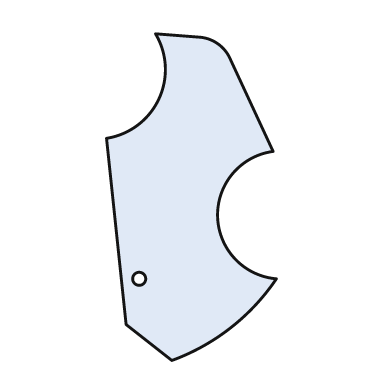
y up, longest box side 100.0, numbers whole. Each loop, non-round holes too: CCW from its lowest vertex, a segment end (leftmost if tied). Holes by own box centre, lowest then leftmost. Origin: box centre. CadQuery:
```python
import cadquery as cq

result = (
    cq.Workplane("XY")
    .moveTo(-6.0, -50.0)
    .threePointArc((12.0, -40.0), (26.0, -25.0))
    .threePointArc((8.0, -6.0), (25.0, 14.0))
    .lineTo(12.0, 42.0)
    .threePointArc((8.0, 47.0), (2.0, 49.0))
    .lineTo(-11.0, 50.0)
    .threePointArc((-10.0, 30.0), (-26.0, 18.0))
    .lineTo(-20.0, -39.0)
    .close()
    .moveTo(-16.0, -25.0)
    .circle(2.0)
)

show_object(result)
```